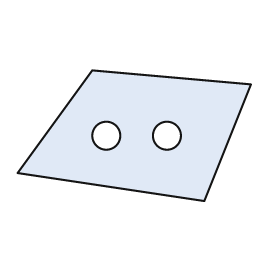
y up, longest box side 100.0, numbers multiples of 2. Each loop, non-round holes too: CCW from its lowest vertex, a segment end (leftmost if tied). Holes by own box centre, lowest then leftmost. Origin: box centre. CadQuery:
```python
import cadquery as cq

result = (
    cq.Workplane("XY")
    .moveTo(30.0, -28.0)
    .lineTo(50.0, 22.0)
    .lineTo(-18.0, 28.0)
    .lineTo(-50.0, -16.0)
    .close()
    .moveTo(-12.0, 0.0)
    .circle(6.0)
    .moveTo(14.0, 0.0)
    .circle(6.0)
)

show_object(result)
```